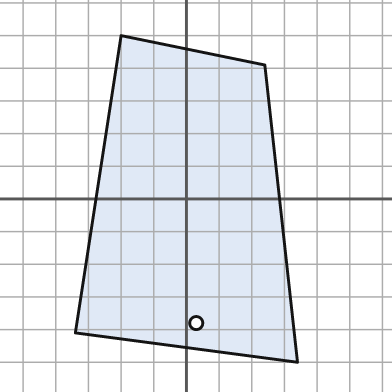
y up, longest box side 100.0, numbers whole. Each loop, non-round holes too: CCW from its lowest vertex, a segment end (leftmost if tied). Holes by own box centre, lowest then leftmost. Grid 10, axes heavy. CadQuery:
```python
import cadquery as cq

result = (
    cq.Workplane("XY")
    .moveTo(34.0, -50.0)
    .lineTo(24.0, 41.0)
    .lineTo(-20.0, 50.0)
    .lineTo(-34.0, -41.0)
    .close()
    .moveTo(3.0, -38.0)
    .circle(2.0)
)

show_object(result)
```